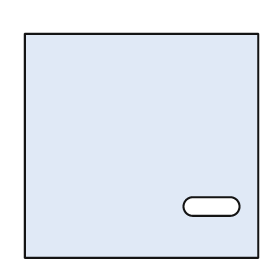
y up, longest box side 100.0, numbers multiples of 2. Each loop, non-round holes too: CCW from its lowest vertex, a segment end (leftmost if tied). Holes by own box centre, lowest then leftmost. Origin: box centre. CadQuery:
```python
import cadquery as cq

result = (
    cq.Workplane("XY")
    .moveTo(-50.0, -48.0)
    .lineTo(50.0, -48.0)
    .lineTo(50.0, 48.0)
    .lineTo(-50.0, 48.0)
    .close()
    .moveTo(22.0, -30.0)
    .lineTo(38.0, -30.0)
    .threePointArc((42.0, -26.0), (38.0, -22.0))
    .lineTo(22.0, -22.0)
    .threePointArc((18.0, -26.0), (22.0, -30.0))
    .close()
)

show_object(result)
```